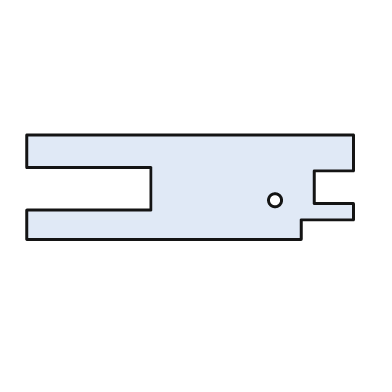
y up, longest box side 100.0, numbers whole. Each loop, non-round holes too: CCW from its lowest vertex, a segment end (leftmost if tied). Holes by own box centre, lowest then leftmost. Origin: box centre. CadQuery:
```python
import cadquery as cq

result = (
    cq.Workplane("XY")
    .moveTo(-50.0, -16.0)
    .lineTo(34.0, -16.0)
    .lineTo(34.0, -10.0)
    .lineTo(50.0, -10.0)
    .lineTo(50.0, -5.0)
    .lineTo(38.0, -5.0)
    .lineTo(38.0, 5.0)
    .lineTo(50.0, 5.0)
    .lineTo(50.0, 16.0)
    .lineTo(-50.0, 16.0)
    .lineTo(-50.0, 6.0)
    .lineTo(-12.0, 6.0)
    .lineTo(-12.0, -7.0)
    .lineTo(-50.0, -7.0)
    .close()
    .moveTo(26.0, -4.0)
    .circle(2.0)
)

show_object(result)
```